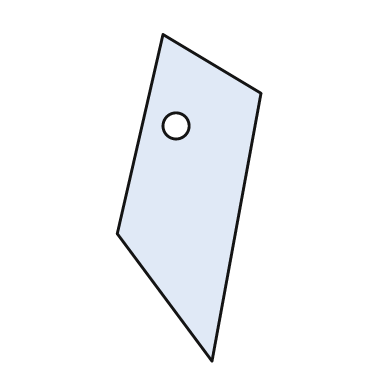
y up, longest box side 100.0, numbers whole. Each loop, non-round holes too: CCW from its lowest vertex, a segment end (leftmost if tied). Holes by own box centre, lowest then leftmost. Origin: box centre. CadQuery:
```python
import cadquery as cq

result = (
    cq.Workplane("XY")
    .moveTo(7.0, -50.0)
    .lineTo(22.0, 32.0)
    .lineTo(-8.0, 50.0)
    .lineTo(-22.0, -11.0)
    .close()
    .moveTo(-4.0, 22.0)
    .circle(4.0)
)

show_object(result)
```